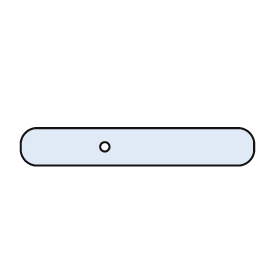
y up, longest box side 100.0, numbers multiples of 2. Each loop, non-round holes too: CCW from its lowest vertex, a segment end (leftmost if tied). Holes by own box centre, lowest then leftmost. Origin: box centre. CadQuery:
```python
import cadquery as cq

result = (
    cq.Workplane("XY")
    .moveTo(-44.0, -8.0)
    .lineTo(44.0, -8.0)
    .threePointArc((48.0, -6.0), (50.0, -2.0))
    .lineTo(50.0, 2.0)
    .threePointArc((48.0, 6.0), (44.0, 8.0))
    .lineTo(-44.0, 8.0)
    .threePointArc((-48.0, 6.0), (-50.0, 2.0))
    .lineTo(-50.0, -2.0)
    .threePointArc((-48.0, -6.0), (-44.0, -8.0))
    .close()
    .moveTo(-14.0, 0.0)
    .circle(2.0)
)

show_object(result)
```